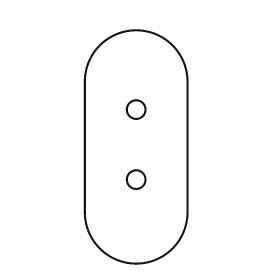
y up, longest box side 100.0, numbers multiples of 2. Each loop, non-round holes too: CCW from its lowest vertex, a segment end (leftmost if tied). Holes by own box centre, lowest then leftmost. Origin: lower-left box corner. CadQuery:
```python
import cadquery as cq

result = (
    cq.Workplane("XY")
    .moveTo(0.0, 22.0)
    .threePointArc((22.0, 0.0), (44.0, 22.0))
    .lineTo(44.0, 78.0)
    .threePointArc((22.0, 100.0), (0.0, 78.0))
    .close()
    .moveTo(22.0, 36.0)
    .circle(4.0)
    .moveTo(22.0, 66.0)
    .circle(4.0)
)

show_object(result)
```